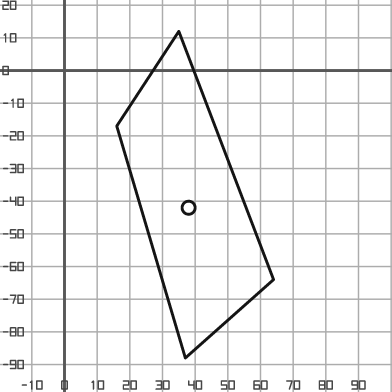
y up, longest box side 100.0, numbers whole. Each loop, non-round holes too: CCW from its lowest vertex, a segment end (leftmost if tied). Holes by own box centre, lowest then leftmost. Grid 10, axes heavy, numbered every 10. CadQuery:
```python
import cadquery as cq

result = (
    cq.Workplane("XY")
    .moveTo(37.0, -88.0)
    .lineTo(64.0, -64.0)
    .lineTo(35.0, 12.0)
    .lineTo(16.0, -17.0)
    .close()
    .moveTo(38.0, -42.0)
    .circle(2.0)
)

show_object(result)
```